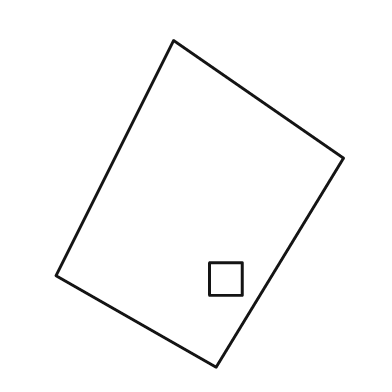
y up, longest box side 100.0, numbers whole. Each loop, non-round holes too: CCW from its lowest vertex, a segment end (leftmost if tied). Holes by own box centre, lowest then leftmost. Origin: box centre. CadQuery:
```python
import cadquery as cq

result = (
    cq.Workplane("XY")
    .moveTo(5.0, -50.0)
    .lineTo(44.0, 14.0)
    .lineTo(-8.0, 50.0)
    .lineTo(-44.0, -22.0)
    .close()
    .moveTo(3.0, -28.0)
    .lineTo(13.0, -28.0)
    .lineTo(13.0, -18.0)
    .lineTo(3.0, -18.0)
    .close()
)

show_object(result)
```